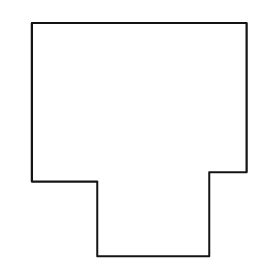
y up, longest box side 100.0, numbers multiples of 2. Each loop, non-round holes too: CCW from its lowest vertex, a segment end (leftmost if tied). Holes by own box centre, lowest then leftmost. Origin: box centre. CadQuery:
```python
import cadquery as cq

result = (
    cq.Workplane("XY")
    .moveTo(-18.0, -50.0)
    .lineTo(30.0, -50.0)
    .lineTo(30.0, -14.0)
    .lineTo(46.0, -14.0)
    .lineTo(46.0, 50.0)
    .lineTo(-46.0, 50.0)
    .lineTo(-46.0, -18.0)
    .lineTo(-18.0, -18.0)
    .close()
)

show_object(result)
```